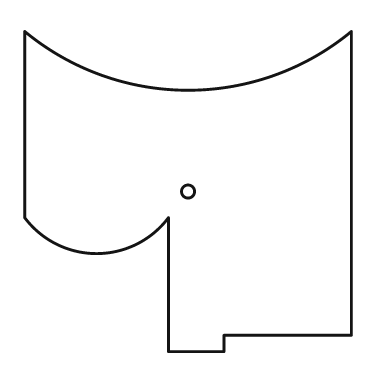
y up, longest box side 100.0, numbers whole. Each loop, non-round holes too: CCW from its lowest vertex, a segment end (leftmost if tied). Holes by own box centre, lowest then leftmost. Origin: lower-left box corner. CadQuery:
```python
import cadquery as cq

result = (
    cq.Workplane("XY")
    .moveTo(44.0, 0.0)
    .lineTo(61.0, 0.0)
    .lineTo(61.0, 5.0)
    .lineTo(100.0, 5.0)
    .lineTo(100.0, 98.0)
    .threePointArc((50.0, 80.0), (0.0, 98.0))
    .lineTo(0.0, 41.0)
    .threePointArc((22.0, 30.0), (44.0, 41.0))
    .close()
    .moveTo(50.0, 49.0)
    .circle(2.0)
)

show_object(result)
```